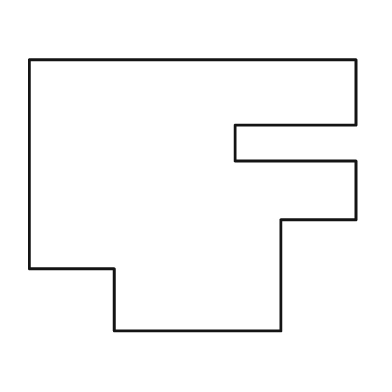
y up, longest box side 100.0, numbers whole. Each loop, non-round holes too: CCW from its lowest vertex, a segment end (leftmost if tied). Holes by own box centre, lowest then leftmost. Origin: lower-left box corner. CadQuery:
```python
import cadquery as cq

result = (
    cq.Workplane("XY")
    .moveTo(26.0, 0.0)
    .lineTo(77.0, 0.0)
    .lineTo(77.0, 34.0)
    .lineTo(100.0, 34.0)
    .lineTo(100.0, 52.0)
    .lineTo(63.0, 52.0)
    .lineTo(63.0, 63.0)
    .lineTo(100.0, 63.0)
    .lineTo(100.0, 83.0)
    .lineTo(0.0, 83.0)
    .lineTo(0.0, 19.0)
    .lineTo(26.0, 19.0)
    .close()
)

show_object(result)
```